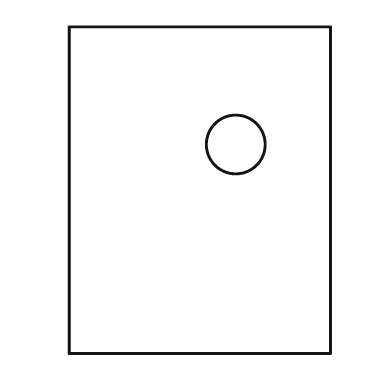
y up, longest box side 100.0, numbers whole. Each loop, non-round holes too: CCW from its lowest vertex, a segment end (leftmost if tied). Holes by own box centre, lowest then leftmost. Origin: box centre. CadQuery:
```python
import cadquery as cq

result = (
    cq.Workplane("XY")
    .moveTo(-40.0, -50.0)
    .lineTo(40.0, -50.0)
    .lineTo(40.0, 50.0)
    .lineTo(-40.0, 50.0)
    .close()
    .moveTo(11.0, 14.0)
    .circle(9.0)
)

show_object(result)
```